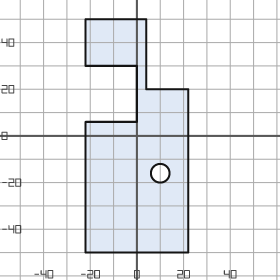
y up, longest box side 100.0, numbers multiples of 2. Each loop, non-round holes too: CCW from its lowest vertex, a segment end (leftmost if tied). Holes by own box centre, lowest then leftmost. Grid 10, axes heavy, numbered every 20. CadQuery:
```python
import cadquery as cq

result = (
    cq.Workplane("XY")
    .moveTo(-22.0, -50.0)
    .lineTo(22.0, -50.0)
    .lineTo(22.0, 20.0)
    .lineTo(4.0, 20.0)
    .lineTo(4.0, 50.0)
    .lineTo(-22.0, 50.0)
    .lineTo(-22.0, 30.0)
    .lineTo(0.0, 30.0)
    .lineTo(0.0, 6.0)
    .lineTo(-22.0, 6.0)
    .close()
    .moveTo(10.0, -16.0)
    .circle(4.0)
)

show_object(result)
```